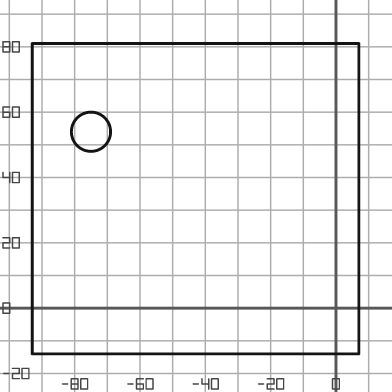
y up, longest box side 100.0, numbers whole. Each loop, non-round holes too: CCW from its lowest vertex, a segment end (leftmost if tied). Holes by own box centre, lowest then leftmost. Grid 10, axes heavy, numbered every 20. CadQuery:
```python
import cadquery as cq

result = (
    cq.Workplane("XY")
    .moveTo(-93.0, -14.0)
    .lineTo(7.0, -14.0)
    .lineTo(7.0, 81.0)
    .lineTo(-93.0, 81.0)
    .close()
    .moveTo(-75.0, 54.0)
    .circle(6.0)
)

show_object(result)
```